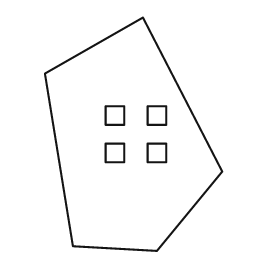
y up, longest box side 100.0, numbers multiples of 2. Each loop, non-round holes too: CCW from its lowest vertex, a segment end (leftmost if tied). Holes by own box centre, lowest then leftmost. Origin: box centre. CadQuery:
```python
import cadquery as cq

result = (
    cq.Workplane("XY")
    .moveTo(10.0, -50.0)
    .lineTo(38.0, -16.0)
    .lineTo(4.0, 50.0)
    .lineTo(-38.0, 26.0)
    .lineTo(-26.0, -48.0)
    .close()
    .moveTo(-12.0, -12.0)
    .lineTo(-4.0, -12.0)
    .lineTo(-4.0, -4.0)
    .lineTo(-12.0, -4.0)
    .close()
    .moveTo(6.0, -12.0)
    .lineTo(14.0, -12.0)
    .lineTo(14.0, -4.0)
    .lineTo(6.0, -4.0)
    .close()
    .moveTo(-12.0, 4.0)
    .lineTo(-4.0, 4.0)
    .lineTo(-4.0, 12.0)
    .lineTo(-12.0, 12.0)
    .close()
    .moveTo(6.0, 4.0)
    .lineTo(14.0, 4.0)
    .lineTo(14.0, 12.0)
    .lineTo(6.0, 12.0)
    .close()
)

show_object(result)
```